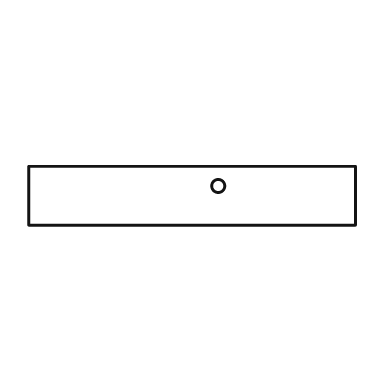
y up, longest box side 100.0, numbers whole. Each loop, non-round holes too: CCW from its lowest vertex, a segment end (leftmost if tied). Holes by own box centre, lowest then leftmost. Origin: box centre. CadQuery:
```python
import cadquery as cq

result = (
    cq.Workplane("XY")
    .moveTo(-50.0, -9.0)
    .lineTo(50.0, -9.0)
    .lineTo(50.0, 9.0)
    .lineTo(-50.0, 9.0)
    .close()
    .moveTo(8.0, 3.0)
    .circle(2.0)
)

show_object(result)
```